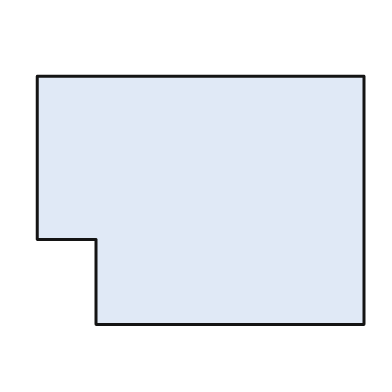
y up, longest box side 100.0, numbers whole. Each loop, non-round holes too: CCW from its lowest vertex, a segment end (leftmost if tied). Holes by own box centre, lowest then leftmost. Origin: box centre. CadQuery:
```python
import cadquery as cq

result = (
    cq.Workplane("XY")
    .moveTo(-32.0, -38.0)
    .lineTo(50.0, -38.0)
    .lineTo(50.0, 38.0)
    .lineTo(-50.0, 38.0)
    .lineTo(-50.0, -12.0)
    .lineTo(-32.0, -12.0)
    .close()
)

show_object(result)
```